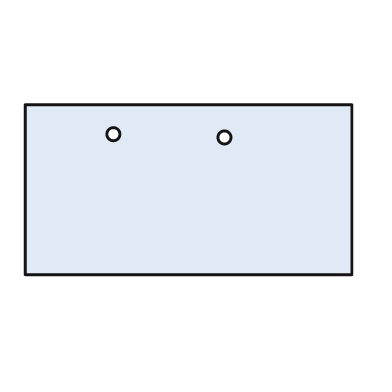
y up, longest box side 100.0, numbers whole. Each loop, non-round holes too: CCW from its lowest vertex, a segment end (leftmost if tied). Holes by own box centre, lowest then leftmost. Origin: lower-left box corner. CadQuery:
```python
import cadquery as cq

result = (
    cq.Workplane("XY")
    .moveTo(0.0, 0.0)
    .lineTo(100.0, 0.0)
    .lineTo(100.0, 52.0)
    .lineTo(0.0, 52.0)
    .close()
    .moveTo(61.0, 42.0)
    .circle(2.0)
    .moveTo(27.0, 43.0)
    .circle(2.0)
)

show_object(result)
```